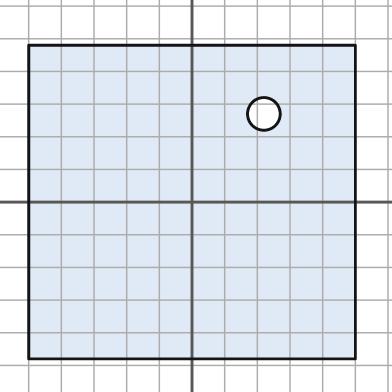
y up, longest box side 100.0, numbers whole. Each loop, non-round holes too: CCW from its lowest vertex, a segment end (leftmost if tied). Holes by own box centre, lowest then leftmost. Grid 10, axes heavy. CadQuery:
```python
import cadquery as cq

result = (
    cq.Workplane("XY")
    .moveTo(-50.0, -48.0)
    .lineTo(50.0, -48.0)
    .lineTo(50.0, 48.0)
    .lineTo(-50.0, 48.0)
    .close()
    .moveTo(22.0, 27.0)
    .circle(5.0)
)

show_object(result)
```